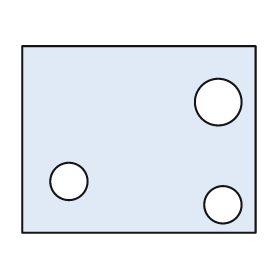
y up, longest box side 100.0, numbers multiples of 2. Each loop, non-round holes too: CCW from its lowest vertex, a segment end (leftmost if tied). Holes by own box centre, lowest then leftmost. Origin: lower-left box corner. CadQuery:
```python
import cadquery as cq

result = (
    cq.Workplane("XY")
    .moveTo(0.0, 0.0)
    .lineTo(100.0, 0.0)
    .lineTo(100.0, 80.0)
    .lineTo(0.0, 80.0)
    .close()
    .moveTo(86.0, 12.0)
    .circle(8.0)
    .moveTo(20.0, 22.0)
    .circle(8.0)
    .moveTo(84.0, 56.0)
    .circle(10.0)
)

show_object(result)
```